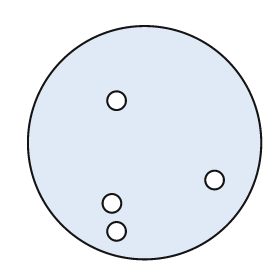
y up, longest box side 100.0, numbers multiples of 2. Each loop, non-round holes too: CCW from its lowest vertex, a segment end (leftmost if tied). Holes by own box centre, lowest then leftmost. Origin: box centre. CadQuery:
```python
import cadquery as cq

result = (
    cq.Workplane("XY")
    .moveTo(0.0, 0.0)
    .circle(50.0)
    .moveTo(-12.0, -38.0)
    .circle(4.0)
    .moveTo(-14.0, -26.0)
    .circle(4.0)
    .moveTo(30.0, -16.0)
    .circle(4.0)
    .moveTo(-12.0, 18.0)
    .circle(4.0)
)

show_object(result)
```